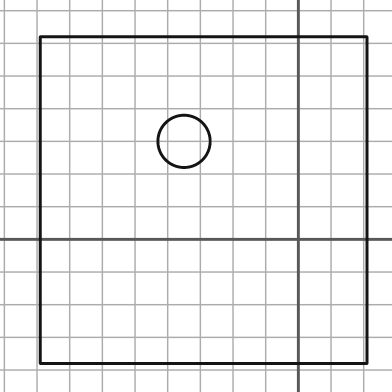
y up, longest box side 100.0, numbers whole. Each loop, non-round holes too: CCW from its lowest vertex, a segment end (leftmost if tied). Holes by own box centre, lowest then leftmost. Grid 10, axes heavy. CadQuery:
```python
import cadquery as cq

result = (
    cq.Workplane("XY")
    .moveTo(-79.0, -38.0)
    .lineTo(21.0, -38.0)
    .lineTo(21.0, 62.0)
    .lineTo(-79.0, 62.0)
    .close()
    .moveTo(-35.0, 30.0)
    .circle(8.0)
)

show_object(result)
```